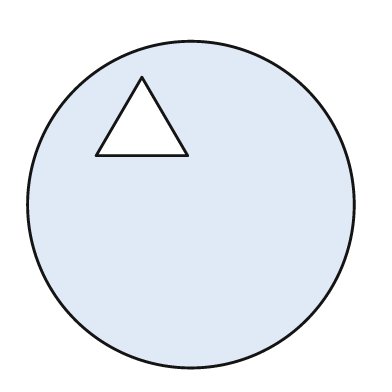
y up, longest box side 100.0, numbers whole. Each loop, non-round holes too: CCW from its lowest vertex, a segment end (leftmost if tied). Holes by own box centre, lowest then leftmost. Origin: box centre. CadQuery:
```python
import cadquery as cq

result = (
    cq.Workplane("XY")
    .moveTo(0.0, 0.0)
    .circle(50.0)
    .moveTo(-29.0, 15.0)
    .lineTo(-1.0, 15.0)
    .lineTo(-15.0, 39.0)
    .close()
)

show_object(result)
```